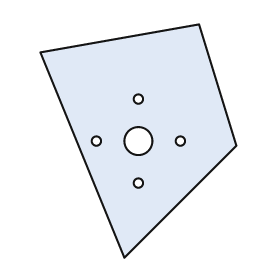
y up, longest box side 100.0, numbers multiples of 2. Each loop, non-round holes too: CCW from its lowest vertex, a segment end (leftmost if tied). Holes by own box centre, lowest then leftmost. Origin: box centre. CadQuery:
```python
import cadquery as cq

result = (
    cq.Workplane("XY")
    .moveTo(-6.0, -50.0)
    .lineTo(42.0, -2.0)
    .lineTo(26.0, 50.0)
    .lineTo(-42.0, 38.0)
    .close()
    .moveTo(0.0, -18.0)
    .circle(2.0)
    .moveTo(-18.0, 0.0)
    .circle(2.0)
    .moveTo(0.0, 0.0)
    .circle(6.0)
    .moveTo(18.0, 0.0)
    .circle(2.0)
    .moveTo(0.0, 18.0)
    .circle(2.0)
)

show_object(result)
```